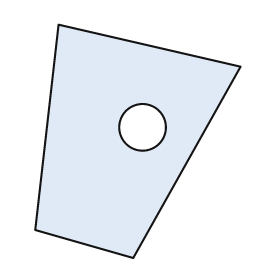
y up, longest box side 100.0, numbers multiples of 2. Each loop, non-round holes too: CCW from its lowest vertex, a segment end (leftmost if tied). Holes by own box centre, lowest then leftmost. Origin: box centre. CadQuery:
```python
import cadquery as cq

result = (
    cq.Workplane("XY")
    .moveTo(-2.0, -50.0)
    .lineTo(44.0, 32.0)
    .lineTo(-34.0, 50.0)
    .lineTo(-44.0, -38.0)
    .close()
    .moveTo(2.0, 6.0)
    .circle(10.0)
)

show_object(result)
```